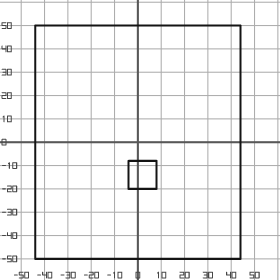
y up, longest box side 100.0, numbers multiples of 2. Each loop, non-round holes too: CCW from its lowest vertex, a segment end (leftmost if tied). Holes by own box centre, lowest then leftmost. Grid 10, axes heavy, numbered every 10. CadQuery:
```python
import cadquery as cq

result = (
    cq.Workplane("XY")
    .moveTo(-44.0, -50.0)
    .lineTo(44.0, -50.0)
    .lineTo(44.0, 50.0)
    .lineTo(-44.0, 50.0)
    .close()
    .moveTo(-4.0, -20.0)
    .lineTo(8.0, -20.0)
    .lineTo(8.0, -8.0)
    .lineTo(-4.0, -8.0)
    .close()
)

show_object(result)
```